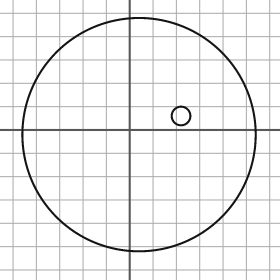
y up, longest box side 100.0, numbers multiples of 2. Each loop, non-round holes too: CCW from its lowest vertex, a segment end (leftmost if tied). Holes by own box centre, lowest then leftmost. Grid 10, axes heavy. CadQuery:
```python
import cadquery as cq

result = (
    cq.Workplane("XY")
    .moveTo(4.0, -2.0)
    .circle(50.0)
    .moveTo(22.0, 6.0)
    .circle(4.0)
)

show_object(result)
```